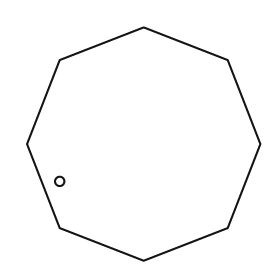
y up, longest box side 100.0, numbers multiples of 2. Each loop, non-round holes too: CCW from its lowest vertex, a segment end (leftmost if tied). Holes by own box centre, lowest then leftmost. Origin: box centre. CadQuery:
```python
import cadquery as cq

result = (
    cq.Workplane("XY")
    .moveTo(0.0, -50.0)
    .lineTo(36.0, -36.0)
    .lineTo(50.0, 0.0)
    .lineTo(36.0, 36.0)
    .lineTo(0.0, 50.0)
    .lineTo(-36.0, 36.0)
    .lineTo(-50.0, 0.0)
    .lineTo(-36.0, -36.0)
    .close()
    .moveTo(-36.0, -16.0)
    .circle(2.0)
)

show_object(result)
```